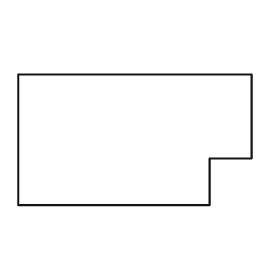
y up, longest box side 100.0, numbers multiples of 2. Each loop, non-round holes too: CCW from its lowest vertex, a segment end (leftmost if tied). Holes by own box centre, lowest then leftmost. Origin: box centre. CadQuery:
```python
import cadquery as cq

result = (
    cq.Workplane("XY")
    .moveTo(-50.0, -28.0)
    .lineTo(32.0, -28.0)
    .lineTo(32.0, -8.0)
    .lineTo(50.0, -8.0)
    .lineTo(50.0, 28.0)
    .lineTo(-50.0, 28.0)
    .close()
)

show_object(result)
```